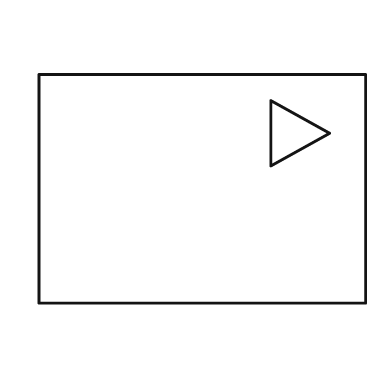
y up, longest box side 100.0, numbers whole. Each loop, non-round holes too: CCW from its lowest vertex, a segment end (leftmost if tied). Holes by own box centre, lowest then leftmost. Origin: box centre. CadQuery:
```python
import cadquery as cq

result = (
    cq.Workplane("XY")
    .moveTo(-50.0, -35.0)
    .lineTo(50.0, -35.0)
    .lineTo(50.0, 35.0)
    .lineTo(-50.0, 35.0)
    .close()
    .moveTo(21.0, 7.0)
    .lineTo(39.0, 17.0)
    .lineTo(21.0, 27.0)
    .close()
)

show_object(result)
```